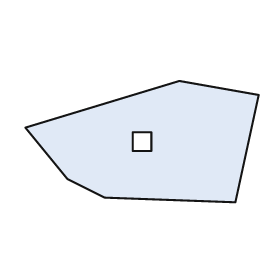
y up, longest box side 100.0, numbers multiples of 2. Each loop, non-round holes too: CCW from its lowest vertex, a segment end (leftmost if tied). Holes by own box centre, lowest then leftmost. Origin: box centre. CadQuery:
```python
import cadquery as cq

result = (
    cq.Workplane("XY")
    .moveTo(40.0, -26.0)
    .lineTo(50.0, 20.0)
    .lineTo(16.0, 26.0)
    .lineTo(-50.0, 6.0)
    .lineTo(-32.0, -16.0)
    .lineTo(-16.0, -24.0)
    .close()
    .moveTo(-4.0, -4.0)
    .lineTo(4.0, -4.0)
    .lineTo(4.0, 4.0)
    .lineTo(-4.0, 4.0)
    .close()
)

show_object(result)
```